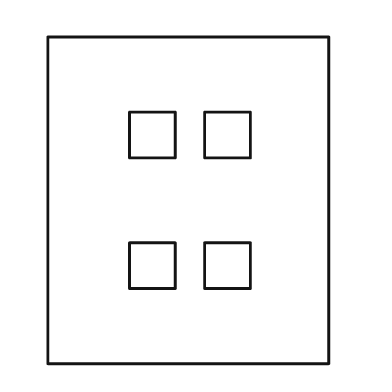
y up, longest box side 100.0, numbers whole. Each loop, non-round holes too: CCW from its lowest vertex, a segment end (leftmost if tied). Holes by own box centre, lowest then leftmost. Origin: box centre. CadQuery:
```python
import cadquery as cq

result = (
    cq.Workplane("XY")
    .moveTo(-43.0, -50.0)
    .lineTo(43.0, -50.0)
    .lineTo(43.0, 50.0)
    .lineTo(-43.0, 50.0)
    .close()
    .moveTo(-18.0, -27.0)
    .lineTo(-4.0, -27.0)
    .lineTo(-4.0, -13.0)
    .lineTo(-18.0, -13.0)
    .close()
    .moveTo(5.0, -27.0)
    .lineTo(19.0, -27.0)
    .lineTo(19.0, -13.0)
    .lineTo(5.0, -13.0)
    .close()
    .moveTo(-18.0, 13.0)
    .lineTo(-4.0, 13.0)
    .lineTo(-4.0, 27.0)
    .lineTo(-18.0, 27.0)
    .close()
    .moveTo(5.0, 13.0)
    .lineTo(19.0, 13.0)
    .lineTo(19.0, 27.0)
    .lineTo(5.0, 27.0)
    .close()
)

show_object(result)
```